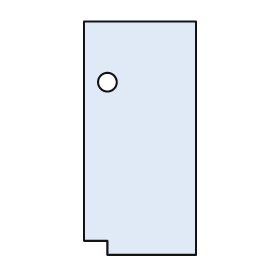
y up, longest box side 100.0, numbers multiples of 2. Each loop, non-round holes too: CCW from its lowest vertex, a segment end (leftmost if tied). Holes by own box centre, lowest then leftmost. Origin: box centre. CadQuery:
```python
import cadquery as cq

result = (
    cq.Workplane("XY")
    .moveTo(-14.0, -50.0)
    .lineTo(24.0, -50.0)
    .lineTo(24.0, 50.0)
    .lineTo(-24.0, 50.0)
    .lineTo(-24.0, -44.0)
    .lineTo(-14.0, -44.0)
    .close()
    .moveTo(-14.0, 24.0)
    .circle(4.0)
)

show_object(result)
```